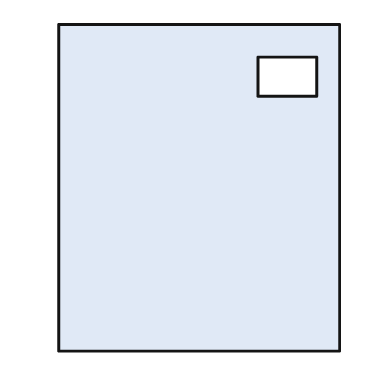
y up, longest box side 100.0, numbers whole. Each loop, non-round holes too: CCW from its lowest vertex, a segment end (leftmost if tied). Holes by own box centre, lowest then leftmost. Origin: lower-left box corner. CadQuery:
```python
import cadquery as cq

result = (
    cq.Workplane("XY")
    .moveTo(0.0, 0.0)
    .lineTo(86.0, 0.0)
    .lineTo(86.0, 100.0)
    .lineTo(0.0, 100.0)
    .close()
    .moveTo(61.0, 78.0)
    .lineTo(79.0, 78.0)
    .lineTo(79.0, 90.0)
    .lineTo(61.0, 90.0)
    .close()
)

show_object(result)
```